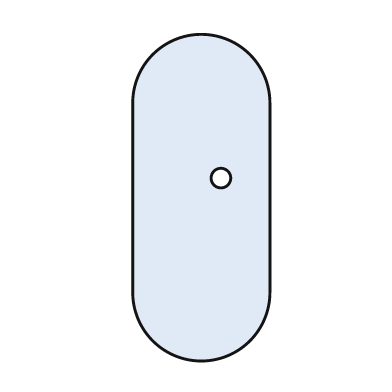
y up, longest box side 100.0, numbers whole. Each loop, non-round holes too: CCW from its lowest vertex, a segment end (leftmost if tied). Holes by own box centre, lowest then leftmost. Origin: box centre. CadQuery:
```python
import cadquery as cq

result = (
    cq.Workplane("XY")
    .moveTo(-21.0, -29.0)
    .threePointArc((0.0, -50.0), (21.0, -29.0))
    .lineTo(21.0, 29.0)
    .threePointArc((0.0, 50.0), (-21.0, 29.0))
    .close()
    .moveTo(6.0, 6.0)
    .circle(3.0)
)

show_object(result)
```